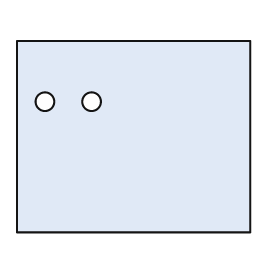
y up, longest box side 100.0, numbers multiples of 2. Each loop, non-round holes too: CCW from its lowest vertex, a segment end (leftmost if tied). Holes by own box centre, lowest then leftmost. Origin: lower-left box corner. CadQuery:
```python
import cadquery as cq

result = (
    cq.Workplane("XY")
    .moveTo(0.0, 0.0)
    .lineTo(100.0, 0.0)
    .lineTo(100.0, 82.0)
    .lineTo(0.0, 82.0)
    .close()
    .moveTo(12.0, 56.0)
    .circle(4.0)
    .moveTo(32.0, 56.0)
    .circle(4.0)
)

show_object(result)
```